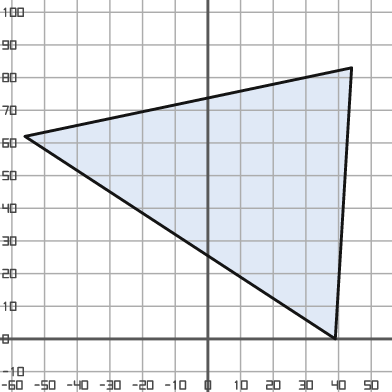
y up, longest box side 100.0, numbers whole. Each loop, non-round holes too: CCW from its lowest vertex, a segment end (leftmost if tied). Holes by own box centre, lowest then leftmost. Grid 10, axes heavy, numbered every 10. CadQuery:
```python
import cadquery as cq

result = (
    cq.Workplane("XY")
    .moveTo(39.0, 0.0)
    .lineTo(44.0, 83.0)
    .lineTo(-56.0, 62.0)
    .close()
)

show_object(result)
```